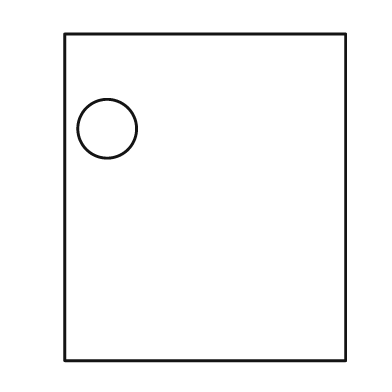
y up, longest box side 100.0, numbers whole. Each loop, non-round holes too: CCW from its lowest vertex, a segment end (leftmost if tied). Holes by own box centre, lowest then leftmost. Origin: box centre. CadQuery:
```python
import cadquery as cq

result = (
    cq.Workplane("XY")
    .moveTo(-43.0, -50.0)
    .lineTo(43.0, -50.0)
    .lineTo(43.0, 50.0)
    .lineTo(-43.0, 50.0)
    .close()
    .moveTo(-30.0, 21.0)
    .circle(9.0)
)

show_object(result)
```